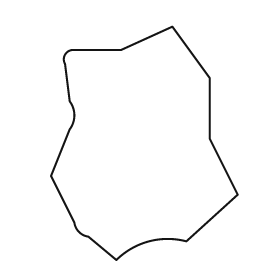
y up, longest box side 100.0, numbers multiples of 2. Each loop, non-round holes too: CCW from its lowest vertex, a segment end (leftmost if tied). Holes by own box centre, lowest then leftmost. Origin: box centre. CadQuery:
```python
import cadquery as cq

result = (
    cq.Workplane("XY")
    .moveTo(-12.0, -50.0)
    .threePointArc((2.0, -42.0), (18.0, -42.0))
    .lineTo(40.0, -22.0)
    .lineTo(28.0, 2.0)
    .lineTo(28.0, 28.0)
    .lineTo(12.0, 50.0)
    .lineTo(-10.0, 40.0)
    .lineTo(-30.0, 40.0)
    .threePointArc((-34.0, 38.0), (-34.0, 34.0))
    .lineTo(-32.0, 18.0)
    .threePointArc((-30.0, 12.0), (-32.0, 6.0))
    .lineTo(-40.0, -14.0)
    .lineTo(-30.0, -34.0)
    .threePointArc((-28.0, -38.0), (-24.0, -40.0))
    .close()
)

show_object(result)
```